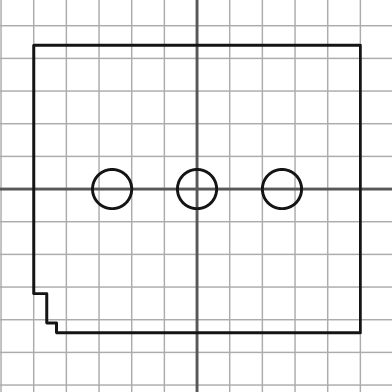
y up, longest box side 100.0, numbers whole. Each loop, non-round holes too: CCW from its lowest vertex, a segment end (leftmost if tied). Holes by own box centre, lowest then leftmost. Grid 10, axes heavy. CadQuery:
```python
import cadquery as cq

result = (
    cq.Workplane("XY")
    .moveTo(-43.0, -44.0)
    .lineTo(50.0, -44.0)
    .lineTo(50.0, 44.0)
    .lineTo(-50.0, 44.0)
    .lineTo(-50.0, -32.0)
    .lineTo(-46.0, -32.0)
    .lineTo(-46.0, -41.0)
    .lineTo(-43.0, -41.0)
    .close()
    .moveTo(-26.0, 0.0)
    .circle(6.0)
    .moveTo(0.0, 0.0)
    .circle(6.0)
    .moveTo(26.0, 0.0)
    .circle(6.0)
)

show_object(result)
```